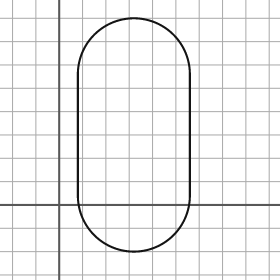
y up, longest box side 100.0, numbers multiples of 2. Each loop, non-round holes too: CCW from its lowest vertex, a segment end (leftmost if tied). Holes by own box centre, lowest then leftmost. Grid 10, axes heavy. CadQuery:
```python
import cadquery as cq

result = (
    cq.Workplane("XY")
    .moveTo(8.0, 4.0)
    .threePointArc((32.0, -20.0), (56.0, 4.0))
    .lineTo(56.0, 56.0)
    .threePointArc((32.0, 80.0), (8.0, 56.0))
    .close()
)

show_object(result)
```